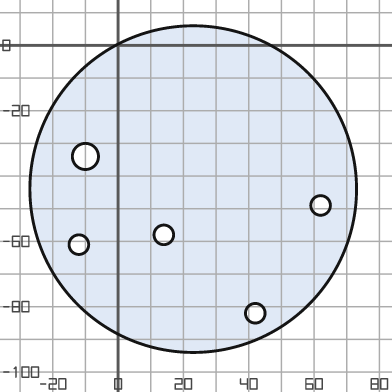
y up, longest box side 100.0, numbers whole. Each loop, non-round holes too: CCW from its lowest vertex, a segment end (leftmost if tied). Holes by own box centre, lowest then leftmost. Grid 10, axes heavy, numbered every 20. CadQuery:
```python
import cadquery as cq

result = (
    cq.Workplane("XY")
    .moveTo(23.0, -44.0)
    .circle(50.0)
    .moveTo(42.0, -82.0)
    .circle(3.0)
    .moveTo(-12.0, -61.0)
    .circle(3.0)
    .moveTo(14.0, -58.0)
    .circle(3.0)
    .moveTo(62.0, -49.0)
    .circle(3.0)
    .moveTo(-10.0, -34.0)
    .circle(4.0)
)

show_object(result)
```